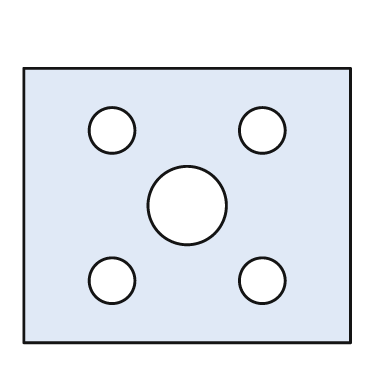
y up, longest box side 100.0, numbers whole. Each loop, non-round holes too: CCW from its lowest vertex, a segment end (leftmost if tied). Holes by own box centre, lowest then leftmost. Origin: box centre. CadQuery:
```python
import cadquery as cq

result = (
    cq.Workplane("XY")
    .moveTo(-50.0, -42.0)
    .lineTo(50.0, -42.0)
    .lineTo(50.0, 42.0)
    .lineTo(-50.0, 42.0)
    .close()
    .moveTo(-23.0, -23.0)
    .circle(7.0)
    .moveTo(23.0, -23.0)
    .circle(7.0)
    .moveTo(0.0, 0.0)
    .circle(12.0)
    .moveTo(-23.0, 23.0)
    .circle(7.0)
    .moveTo(23.0, 23.0)
    .circle(7.0)
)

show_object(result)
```